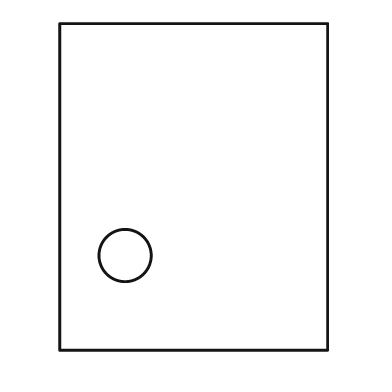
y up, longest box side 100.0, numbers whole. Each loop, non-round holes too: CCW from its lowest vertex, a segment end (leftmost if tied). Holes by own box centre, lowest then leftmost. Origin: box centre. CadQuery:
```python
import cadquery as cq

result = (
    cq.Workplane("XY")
    .moveTo(-41.0, -50.0)
    .lineTo(41.0, -50.0)
    .lineTo(41.0, 50.0)
    .lineTo(-41.0, 50.0)
    .close()
    .moveTo(-21.0, -21.0)
    .circle(8.0)
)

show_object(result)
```